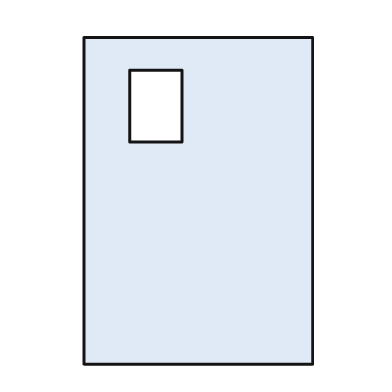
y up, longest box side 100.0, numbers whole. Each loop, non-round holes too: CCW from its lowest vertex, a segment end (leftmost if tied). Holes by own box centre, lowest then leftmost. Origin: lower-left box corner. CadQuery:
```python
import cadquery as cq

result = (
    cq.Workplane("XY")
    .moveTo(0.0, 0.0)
    .lineTo(70.0, 0.0)
    .lineTo(70.0, 100.0)
    .lineTo(0.0, 100.0)
    .close()
    .moveTo(14.0, 68.0)
    .lineTo(30.0, 68.0)
    .lineTo(30.0, 90.0)
    .lineTo(14.0, 90.0)
    .close()
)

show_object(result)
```